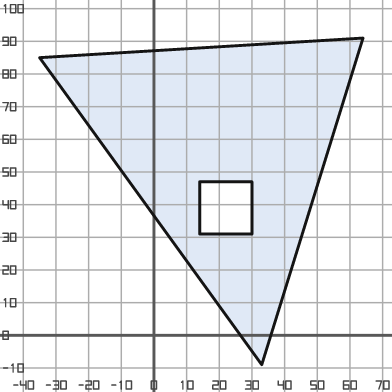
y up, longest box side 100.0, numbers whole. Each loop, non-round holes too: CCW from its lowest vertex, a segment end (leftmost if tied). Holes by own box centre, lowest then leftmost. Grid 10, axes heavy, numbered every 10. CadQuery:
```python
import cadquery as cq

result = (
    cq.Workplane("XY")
    .moveTo(33.0, -9.0)
    .lineTo(64.0, 91.0)
    .lineTo(-35.0, 85.0)
    .close()
    .moveTo(14.0, 31.0)
    .lineTo(30.0, 31.0)
    .lineTo(30.0, 47.0)
    .lineTo(14.0, 47.0)
    .close()
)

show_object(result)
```